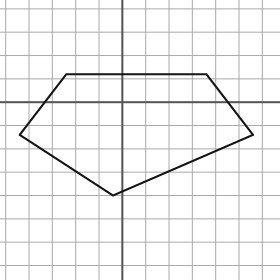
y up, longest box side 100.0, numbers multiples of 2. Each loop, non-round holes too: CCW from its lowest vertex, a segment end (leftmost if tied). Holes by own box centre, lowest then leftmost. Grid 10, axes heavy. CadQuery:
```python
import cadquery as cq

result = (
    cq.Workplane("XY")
    .moveTo(-4.0, -40.0)
    .lineTo(56.0, -14.0)
    .lineTo(36.0, 12.0)
    .lineTo(-24.0, 12.0)
    .lineTo(-44.0, -14.0)
    .close()
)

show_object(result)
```